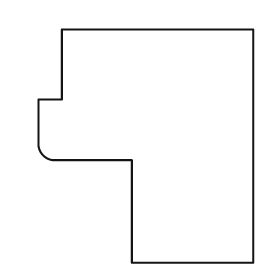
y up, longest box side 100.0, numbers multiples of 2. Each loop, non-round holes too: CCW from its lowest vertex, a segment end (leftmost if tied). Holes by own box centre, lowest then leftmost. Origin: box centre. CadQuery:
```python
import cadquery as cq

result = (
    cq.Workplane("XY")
    .moveTo(-6.0, -50.0)
    .lineTo(46.0, -50.0)
    .lineTo(46.0, 50.0)
    .lineTo(-36.0, 50.0)
    .lineTo(-36.0, 20.0)
    .lineTo(-46.0, 20.0)
    .lineTo(-46.0, 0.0)
    .threePointArc((-44.0, -4.0), (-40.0, -6.0))
    .lineTo(-6.0, -6.0)
    .close()
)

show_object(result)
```